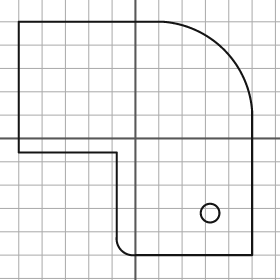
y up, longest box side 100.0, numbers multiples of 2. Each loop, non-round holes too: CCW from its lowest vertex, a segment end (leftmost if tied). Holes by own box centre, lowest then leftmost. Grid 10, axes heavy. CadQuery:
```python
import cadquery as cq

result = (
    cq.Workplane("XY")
    .moveTo(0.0, -50.0)
    .lineTo(50.0, -50.0)
    .lineTo(50.0, 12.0)
    .threePointArc((38.0, 38.0), (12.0, 50.0))
    .lineTo(-50.0, 50.0)
    .lineTo(-50.0, -6.0)
    .lineTo(-8.0, -6.0)
    .lineTo(-8.0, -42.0)
    .threePointArc((-6.0, -48.0), (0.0, -50.0))
    .close()
    .moveTo(32.0, -32.0)
    .circle(4.0)
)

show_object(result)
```